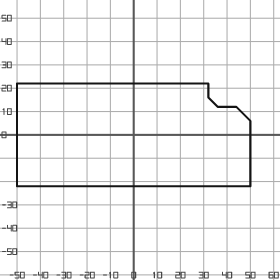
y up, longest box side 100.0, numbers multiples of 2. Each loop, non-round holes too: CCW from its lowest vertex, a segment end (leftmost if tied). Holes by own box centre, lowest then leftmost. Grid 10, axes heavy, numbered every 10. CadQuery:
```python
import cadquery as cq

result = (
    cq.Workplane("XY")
    .moveTo(-50.0, -22.0)
    .lineTo(50.0, -22.0)
    .lineTo(50.0, 6.0)
    .lineTo(44.0, 12.0)
    .lineTo(36.0, 12.0)
    .lineTo(32.0, 16.0)
    .lineTo(32.0, 22.0)
    .lineTo(-50.0, 22.0)
    .close()
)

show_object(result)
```